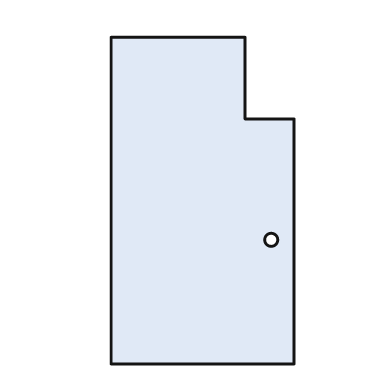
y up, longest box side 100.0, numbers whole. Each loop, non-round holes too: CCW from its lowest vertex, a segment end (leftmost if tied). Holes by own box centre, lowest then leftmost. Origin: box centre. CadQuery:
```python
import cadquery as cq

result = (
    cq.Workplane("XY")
    .moveTo(-28.0, -50.0)
    .lineTo(28.0, -50.0)
    .lineTo(28.0, 25.0)
    .lineTo(13.0, 25.0)
    .lineTo(13.0, 50.0)
    .lineTo(-28.0, 50.0)
    .close()
    .moveTo(21.0, -12.0)
    .circle(2.0)
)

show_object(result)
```